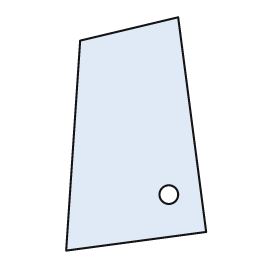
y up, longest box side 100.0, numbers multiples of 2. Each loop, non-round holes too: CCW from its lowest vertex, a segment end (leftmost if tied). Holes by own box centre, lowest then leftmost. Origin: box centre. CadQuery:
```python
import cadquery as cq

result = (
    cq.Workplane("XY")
    .moveTo(-30.0, -50.0)
    .lineTo(30.0, -42.0)
    .lineTo(18.0, 50.0)
    .lineTo(-24.0, 40.0)
    .close()
    .moveTo(14.0, -26.0)
    .circle(4.0)
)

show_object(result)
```